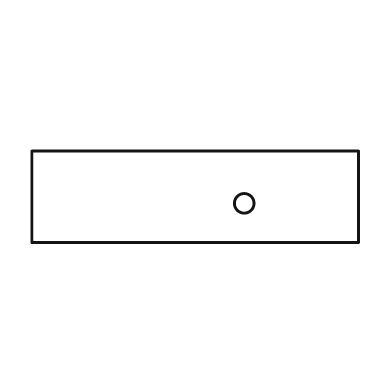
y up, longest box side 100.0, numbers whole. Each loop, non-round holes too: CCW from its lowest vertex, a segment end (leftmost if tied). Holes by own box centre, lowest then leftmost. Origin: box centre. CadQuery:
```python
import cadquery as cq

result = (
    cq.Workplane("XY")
    .moveTo(-50.0, -14.0)
    .lineTo(50.0, -14.0)
    .lineTo(50.0, 14.0)
    .lineTo(-50.0, 14.0)
    .close()
    .moveTo(15.0, -2.0)
    .circle(3.0)
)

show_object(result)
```